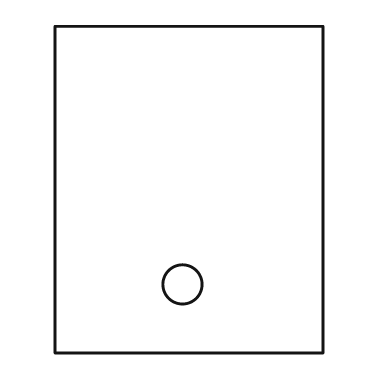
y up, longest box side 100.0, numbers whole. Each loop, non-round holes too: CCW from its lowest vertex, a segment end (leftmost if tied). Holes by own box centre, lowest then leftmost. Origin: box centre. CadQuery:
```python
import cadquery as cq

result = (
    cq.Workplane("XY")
    .moveTo(-41.0, -50.0)
    .lineTo(41.0, -50.0)
    .lineTo(41.0, 50.0)
    .lineTo(-41.0, 50.0)
    .close()
    .moveTo(-2.0, -29.0)
    .circle(6.0)
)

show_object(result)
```